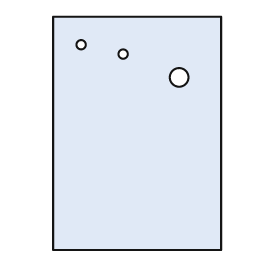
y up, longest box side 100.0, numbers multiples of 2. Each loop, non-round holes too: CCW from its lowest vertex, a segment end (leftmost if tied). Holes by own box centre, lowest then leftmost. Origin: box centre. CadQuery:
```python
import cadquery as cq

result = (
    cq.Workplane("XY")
    .moveTo(-36.0, -50.0)
    .lineTo(36.0, -50.0)
    .lineTo(36.0, 50.0)
    .lineTo(-36.0, 50.0)
    .close()
    .moveTo(18.0, 24.0)
    .circle(4.0)
    .moveTo(-6.0, 34.0)
    .circle(2.0)
    .moveTo(-24.0, 38.0)
    .circle(2.0)
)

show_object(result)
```